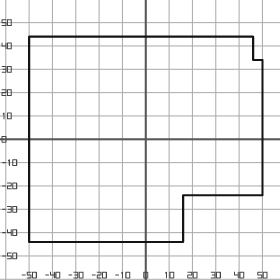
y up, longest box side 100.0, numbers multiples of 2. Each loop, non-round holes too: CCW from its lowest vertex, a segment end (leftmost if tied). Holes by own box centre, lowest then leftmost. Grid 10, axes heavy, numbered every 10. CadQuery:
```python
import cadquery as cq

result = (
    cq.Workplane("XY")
    .moveTo(-50.0, -44.0)
    .lineTo(16.0, -44.0)
    .lineTo(16.0, -24.0)
    .lineTo(50.0, -24.0)
    .lineTo(50.0, 34.0)
    .lineTo(46.0, 34.0)
    .lineTo(46.0, 44.0)
    .lineTo(-50.0, 44.0)
    .close()
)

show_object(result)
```